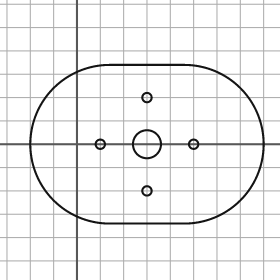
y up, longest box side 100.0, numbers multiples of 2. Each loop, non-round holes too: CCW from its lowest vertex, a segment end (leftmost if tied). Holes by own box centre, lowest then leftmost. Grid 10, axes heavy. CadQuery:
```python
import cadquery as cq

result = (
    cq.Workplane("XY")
    .moveTo(14.0, -34.0)
    .lineTo(46.0, -34.0)
    .threePointArc((80.0, 0.0), (46.0, 34.0))
    .lineTo(14.0, 34.0)
    .threePointArc((-20.0, 0.0), (14.0, -34.0))
    .close()
    .moveTo(30.0, -20.0)
    .circle(2.0)
    .moveTo(10.0, 0.0)
    .circle(2.0)
    .moveTo(30.0, 0.0)
    .circle(6.0)
    .moveTo(50.0, 0.0)
    .circle(2.0)
    .moveTo(30.0, 20.0)
    .circle(2.0)
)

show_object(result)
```